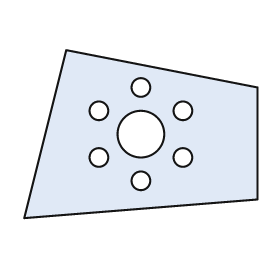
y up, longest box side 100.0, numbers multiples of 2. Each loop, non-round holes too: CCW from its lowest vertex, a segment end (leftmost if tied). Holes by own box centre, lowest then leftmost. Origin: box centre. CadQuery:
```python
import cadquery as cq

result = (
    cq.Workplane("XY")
    .moveTo(-50.0, -36.0)
    .lineTo(50.0, -28.0)
    .lineTo(50.0, 20.0)
    .lineTo(-32.0, 36.0)
    .close()
    .moveTo(0.0, -20.0)
    .circle(4.0)
    .moveTo(-18.0, -10.0)
    .circle(4.0)
    .moveTo(18.0, -10.0)
    .circle(4.0)
    .moveTo(0.0, 0.0)
    .circle(10.0)
    .moveTo(-18.0, 10.0)
    .circle(4.0)
    .moveTo(18.0, 10.0)
    .circle(4.0)
    .moveTo(0.0, 20.0)
    .circle(4.0)
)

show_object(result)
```